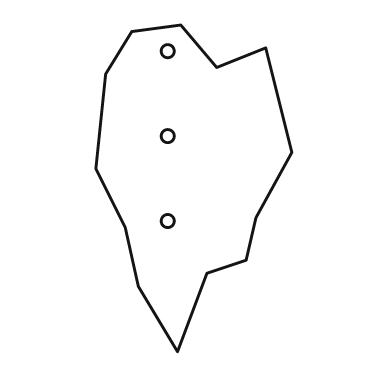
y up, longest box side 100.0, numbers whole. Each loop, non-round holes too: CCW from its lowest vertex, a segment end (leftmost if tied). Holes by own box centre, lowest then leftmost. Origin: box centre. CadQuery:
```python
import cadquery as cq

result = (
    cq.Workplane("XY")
    .moveTo(-5.0, -50.0)
    .lineTo(4.0, -26.0)
    .lineTo(16.0, -22.0)
    .lineTo(19.0, -9.0)
    .lineTo(30.0, 11.0)
    .lineTo(22.0, 43.0)
    .lineTo(7.0, 37.0)
    .lineTo(-4.0, 50.0)
    .lineTo(-19.0, 48.0)
    .lineTo(-27.0, 35.0)
    .lineTo(-30.0, 6.0)
    .lineTo(-21.0, -12.0)
    .lineTo(-17.0, -30.0)
    .close()
    .moveTo(-8.0, -10.0)
    .circle(2.0)
    .moveTo(-8.0, 16.0)
    .circle(2.0)
    .moveTo(-8.0, 42.0)
    .circle(2.0)
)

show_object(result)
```